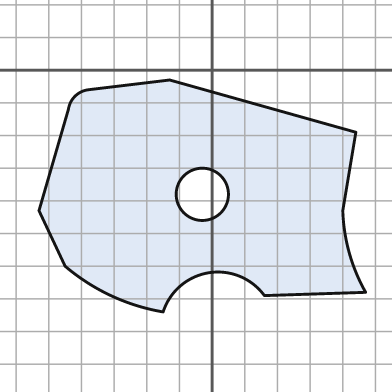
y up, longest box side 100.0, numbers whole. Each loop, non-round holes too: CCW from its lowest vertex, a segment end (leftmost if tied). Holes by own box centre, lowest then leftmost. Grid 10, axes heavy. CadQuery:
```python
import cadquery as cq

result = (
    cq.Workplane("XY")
    .moveTo(-15.0, -74.0)
    .threePointArc((-1.0, -62.0), (16.0, -69.0))
    .lineTo(47.0, -68.0)
    .threePointArc((42.0, -56.0), (40.0, -43.0))
    .lineTo(44.0, -19.0)
    .lineTo(-13.0, -3.0)
    .lineTo(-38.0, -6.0)
    .threePointArc((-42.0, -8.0), (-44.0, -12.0))
    .lineTo(-53.0, -43.0)
    .lineTo(-45.0, -60.0)
    .threePointArc((-31.0, -69.0), (-15.0, -74.0))
    .close()
    .moveTo(-3.0, -38.0)
    .circle(8.0)
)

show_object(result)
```